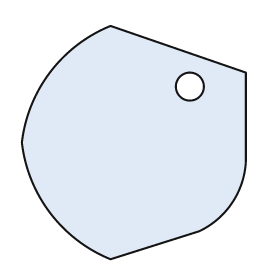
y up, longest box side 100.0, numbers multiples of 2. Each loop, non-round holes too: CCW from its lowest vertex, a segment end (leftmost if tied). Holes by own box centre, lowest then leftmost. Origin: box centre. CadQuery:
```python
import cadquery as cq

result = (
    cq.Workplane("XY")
    .moveTo(-10.0, -50.0)
    .lineTo(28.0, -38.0)
    .threePointArc((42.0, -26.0), (48.0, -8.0))
    .lineTo(48.0, 30.0)
    .lineTo(-10.0, 50.0)
    .threePointArc((-36.0, 30.0), (-48.0, 0.0))
    .threePointArc((-36.0, -30.0), (-10.0, -50.0))
    .close()
    .moveTo(24.0, 24.0)
    .circle(6.0)
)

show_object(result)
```